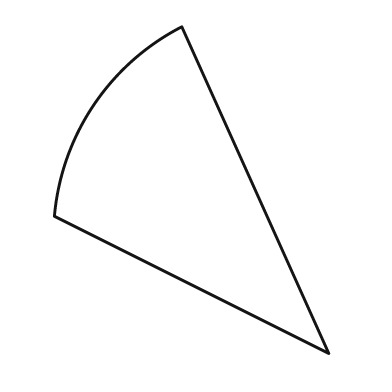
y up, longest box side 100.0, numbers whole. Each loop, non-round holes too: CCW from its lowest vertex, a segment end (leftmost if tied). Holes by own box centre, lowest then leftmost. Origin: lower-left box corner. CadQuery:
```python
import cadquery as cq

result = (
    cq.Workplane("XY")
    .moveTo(84.0, 0.0)
    .lineTo(39.0, 100.0)
    .threePointArc((12.0, 76.0), (0.0, 42.0))
    .close()
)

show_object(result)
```